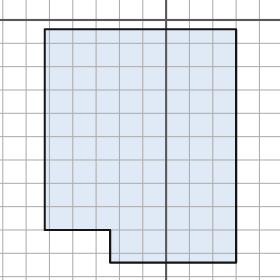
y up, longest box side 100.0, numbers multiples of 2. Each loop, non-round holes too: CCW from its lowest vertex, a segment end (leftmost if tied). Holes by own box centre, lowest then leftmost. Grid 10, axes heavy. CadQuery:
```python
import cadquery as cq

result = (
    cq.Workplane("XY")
    .moveTo(-24.0, -104.0)
    .lineTo(30.0, -104.0)
    .lineTo(30.0, -4.0)
    .lineTo(-52.0, -4.0)
    .lineTo(-52.0, -90.0)
    .lineTo(-24.0, -90.0)
    .close()
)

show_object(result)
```